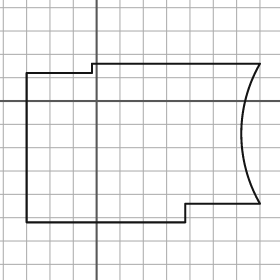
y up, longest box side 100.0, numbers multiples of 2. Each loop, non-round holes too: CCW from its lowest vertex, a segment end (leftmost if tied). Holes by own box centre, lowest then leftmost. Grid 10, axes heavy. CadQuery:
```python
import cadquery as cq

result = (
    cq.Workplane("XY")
    .moveTo(-30.0, -52.0)
    .lineTo(38.0, -52.0)
    .lineTo(38.0, -44.0)
    .lineTo(70.0, -44.0)
    .threePointArc((62.0, -14.0), (70.0, 16.0))
    .lineTo(-2.0, 16.0)
    .lineTo(-2.0, 12.0)
    .lineTo(-30.0, 12.0)
    .close()
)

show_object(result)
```